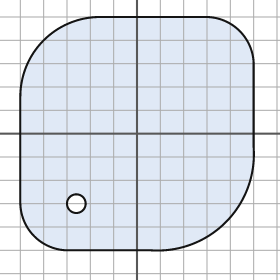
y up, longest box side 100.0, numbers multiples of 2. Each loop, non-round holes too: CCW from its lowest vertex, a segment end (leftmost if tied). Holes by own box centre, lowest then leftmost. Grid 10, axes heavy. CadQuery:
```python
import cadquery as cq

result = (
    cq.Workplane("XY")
    .moveTo(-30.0, -50.0)
    .lineTo(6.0, -50.0)
    .threePointArc((38.0, -38.0), (50.0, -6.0))
    .lineTo(50.0, 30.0)
    .threePointArc((44.0, 44.0), (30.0, 50.0))
    .lineTo(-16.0, 50.0)
    .threePointArc((-40.0, 40.0), (-50.0, 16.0))
    .lineTo(-50.0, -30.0)
    .threePointArc((-44.0, -44.0), (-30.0, -50.0))
    .close()
    .moveTo(-26.0, -30.0)
    .circle(4.0)
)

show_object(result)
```